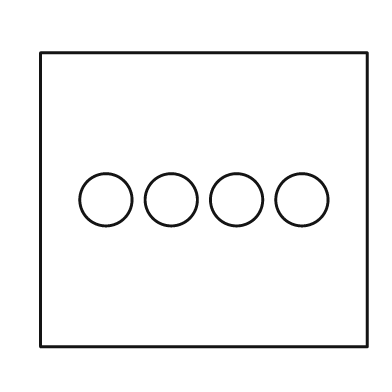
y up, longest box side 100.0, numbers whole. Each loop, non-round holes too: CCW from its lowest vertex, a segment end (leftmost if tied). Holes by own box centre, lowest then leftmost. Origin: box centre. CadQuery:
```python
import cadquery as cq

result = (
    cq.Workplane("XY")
    .moveTo(-50.0, -45.0)
    .lineTo(50.0, -45.0)
    .lineTo(50.0, 45.0)
    .lineTo(-50.0, 45.0)
    .close()
    .moveTo(-30.0, 0.0)
    .circle(8.0)
    .moveTo(-10.0, 0.0)
    .circle(8.0)
    .moveTo(10.0, 0.0)
    .circle(8.0)
    .moveTo(30.0, 0.0)
    .circle(8.0)
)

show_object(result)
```